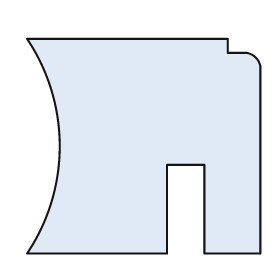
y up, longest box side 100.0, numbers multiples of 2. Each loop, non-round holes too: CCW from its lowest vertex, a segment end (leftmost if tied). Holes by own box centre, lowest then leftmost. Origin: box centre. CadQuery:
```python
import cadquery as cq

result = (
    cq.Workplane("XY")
    .moveTo(-50.0, -46.0)
    .lineTo(10.0, -46.0)
    .lineTo(10.0, -8.0)
    .lineTo(26.0, -8.0)
    .lineTo(26.0, -46.0)
    .lineTo(50.0, -46.0)
    .lineTo(50.0, 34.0)
    .threePointArc((48.0, 38.0), (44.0, 40.0))
    .lineTo(36.0, 40.0)
    .lineTo(36.0, 46.0)
    .lineTo(-50.0, 46.0)
    .threePointArc((-36.0, 0.0), (-50.0, -46.0))
    .close()
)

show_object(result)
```